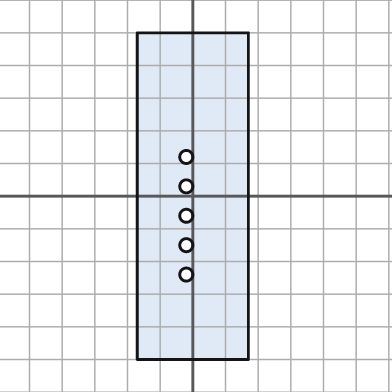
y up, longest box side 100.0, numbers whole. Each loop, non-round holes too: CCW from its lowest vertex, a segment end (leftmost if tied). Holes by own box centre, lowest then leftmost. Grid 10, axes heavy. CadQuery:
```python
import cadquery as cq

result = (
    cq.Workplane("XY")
    .moveTo(-17.0, -50.0)
    .lineTo(17.0, -50.0)
    .lineTo(17.0, 50.0)
    .lineTo(-17.0, 50.0)
    .close()
    .moveTo(-2.0, -24.0)
    .circle(2.0)
    .moveTo(-2.0, -15.0)
    .circle(2.0)
    .moveTo(-2.0, -6.0)
    .circle(2.0)
    .moveTo(-2.0, 3.0)
    .circle(2.0)
    .moveTo(-2.0, 12.0)
    .circle(2.0)
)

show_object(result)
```